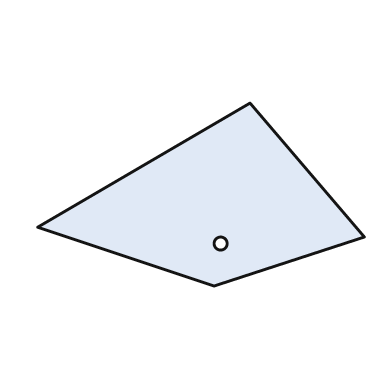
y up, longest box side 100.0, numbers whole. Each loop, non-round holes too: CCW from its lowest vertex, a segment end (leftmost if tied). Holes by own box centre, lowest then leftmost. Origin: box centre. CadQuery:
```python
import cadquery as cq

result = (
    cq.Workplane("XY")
    .moveTo(4.0, -28.0)
    .lineTo(50.0, -13.0)
    .lineTo(15.0, 28.0)
    .lineTo(-50.0, -10.0)
    .close()
    .moveTo(6.0, -15.0)
    .circle(2.0)
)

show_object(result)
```